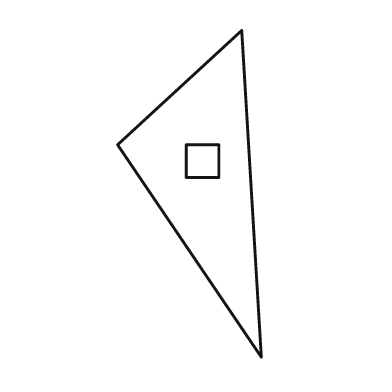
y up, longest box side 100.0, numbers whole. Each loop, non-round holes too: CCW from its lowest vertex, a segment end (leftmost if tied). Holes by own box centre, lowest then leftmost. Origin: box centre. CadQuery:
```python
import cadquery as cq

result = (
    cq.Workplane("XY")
    .moveTo(22.0, -50.0)
    .lineTo(16.0, 50.0)
    .lineTo(-22.0, 15.0)
    .close()
    .moveTo(-1.0, 5.0)
    .lineTo(9.0, 5.0)
    .lineTo(9.0, 15.0)
    .lineTo(-1.0, 15.0)
    .close()
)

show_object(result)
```